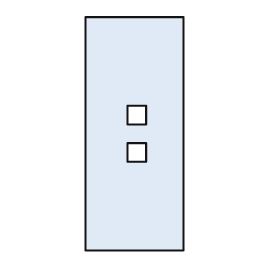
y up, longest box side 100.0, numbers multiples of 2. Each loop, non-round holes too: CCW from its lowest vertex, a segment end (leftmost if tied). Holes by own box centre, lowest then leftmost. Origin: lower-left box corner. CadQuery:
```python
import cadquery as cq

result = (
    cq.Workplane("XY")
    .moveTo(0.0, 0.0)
    .lineTo(42.0, 0.0)
    .lineTo(42.0, 100.0)
    .lineTo(0.0, 100.0)
    .close()
    .moveTo(18.0, 38.0)
    .lineTo(26.0, 38.0)
    .lineTo(26.0, 46.0)
    .lineTo(18.0, 46.0)
    .close()
    .moveTo(18.0, 54.0)
    .lineTo(26.0, 54.0)
    .lineTo(26.0, 62.0)
    .lineTo(18.0, 62.0)
    .close()
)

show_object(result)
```